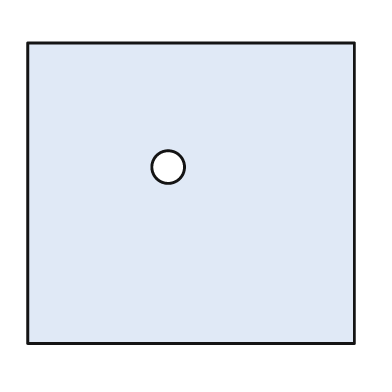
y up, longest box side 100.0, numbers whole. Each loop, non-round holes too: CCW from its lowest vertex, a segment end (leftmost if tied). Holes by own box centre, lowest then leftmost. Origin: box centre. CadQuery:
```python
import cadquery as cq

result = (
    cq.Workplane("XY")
    .moveTo(-50.0, -46.0)
    .lineTo(50.0, -46.0)
    .lineTo(50.0, 46.0)
    .lineTo(-50.0, 46.0)
    .close()
    .moveTo(-7.0, 8.0)
    .circle(5.0)
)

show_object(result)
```